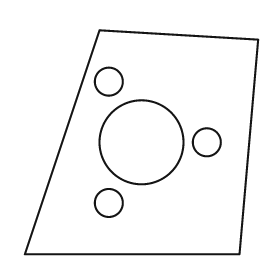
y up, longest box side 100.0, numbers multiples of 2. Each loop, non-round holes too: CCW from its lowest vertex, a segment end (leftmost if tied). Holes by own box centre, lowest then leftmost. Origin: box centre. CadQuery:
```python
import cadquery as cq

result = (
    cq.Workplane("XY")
    .moveTo(-50.0, -48.0)
    .lineTo(42.0, -48.0)
    .lineTo(50.0, 44.0)
    .lineTo(-18.0, 48.0)
    .close()
    .moveTo(-14.0, -26.0)
    .circle(6.0)
    .moveTo(0.0, 0.0)
    .circle(18.0)
    .moveTo(28.0, 0.0)
    .circle(6.0)
    .moveTo(-14.0, 26.0)
    .circle(6.0)
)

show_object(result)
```